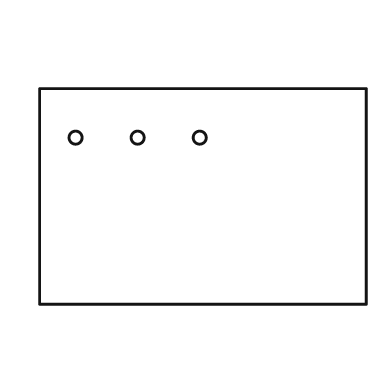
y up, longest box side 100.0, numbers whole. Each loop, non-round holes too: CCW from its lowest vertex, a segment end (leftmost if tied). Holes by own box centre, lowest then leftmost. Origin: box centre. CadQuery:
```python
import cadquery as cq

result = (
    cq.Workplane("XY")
    .moveTo(-50.0, -33.0)
    .lineTo(50.0, -33.0)
    .lineTo(50.0, 33.0)
    .lineTo(-50.0, 33.0)
    .close()
    .moveTo(-39.0, 18.0)
    .circle(2.0)
    .moveTo(-20.0, 18.0)
    .circle(2.0)
    .moveTo(-1.0, 18.0)
    .circle(2.0)
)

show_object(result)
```